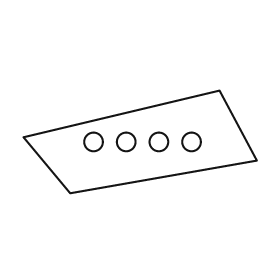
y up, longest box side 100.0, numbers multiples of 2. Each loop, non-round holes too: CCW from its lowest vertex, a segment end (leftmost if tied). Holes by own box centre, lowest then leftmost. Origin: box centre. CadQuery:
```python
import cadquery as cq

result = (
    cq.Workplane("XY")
    .moveTo(-30.0, -22.0)
    .lineTo(50.0, -8.0)
    .lineTo(34.0, 22.0)
    .lineTo(-50.0, 2.0)
    .close()
    .moveTo(-20.0, 0.0)
    .circle(4.0)
    .moveTo(-6.0, 0.0)
    .circle(4.0)
    .moveTo(8.0, 0.0)
    .circle(4.0)
    .moveTo(22.0, 0.0)
    .circle(4.0)
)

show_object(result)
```